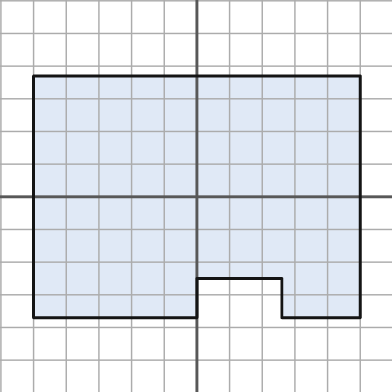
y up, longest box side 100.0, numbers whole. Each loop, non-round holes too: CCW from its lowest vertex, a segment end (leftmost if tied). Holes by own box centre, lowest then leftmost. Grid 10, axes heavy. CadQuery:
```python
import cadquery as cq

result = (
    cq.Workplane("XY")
    .moveTo(-50.0, -37.0)
    .lineTo(0.0, -37.0)
    .lineTo(0.0, -25.0)
    .lineTo(26.0, -25.0)
    .lineTo(26.0, -37.0)
    .lineTo(50.0, -37.0)
    .lineTo(50.0, 37.0)
    .lineTo(-50.0, 37.0)
    .close()
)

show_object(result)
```